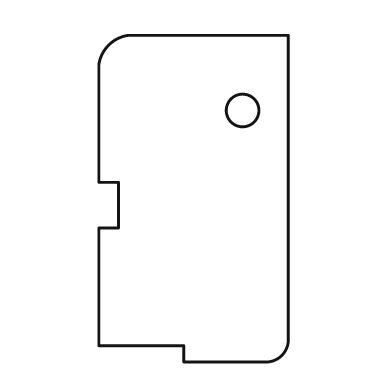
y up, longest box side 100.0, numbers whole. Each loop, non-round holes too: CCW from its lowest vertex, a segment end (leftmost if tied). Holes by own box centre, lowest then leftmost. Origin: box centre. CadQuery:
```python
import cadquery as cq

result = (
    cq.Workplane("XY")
    .moveTo(-3.0, -50.0)
    .lineTo(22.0, -50.0)
    .threePointArc((27.0, -48.0), (29.0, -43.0))
    .lineTo(29.0, 50.0)
    .lineTo(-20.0, 50.0)
    .threePointArc((-26.0, 47.0), (-29.0, 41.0))
    .lineTo(-29.0, 5.0)
    .lineTo(-23.0, 5.0)
    .lineTo(-23.0, -9.0)
    .lineTo(-29.0, -9.0)
    .lineTo(-29.0, -45.0)
    .lineTo(-3.0, -45.0)
    .close()
    .moveTo(15.0, 27.0)
    .circle(5.0)
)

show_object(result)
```